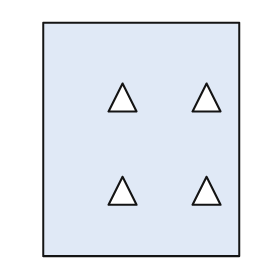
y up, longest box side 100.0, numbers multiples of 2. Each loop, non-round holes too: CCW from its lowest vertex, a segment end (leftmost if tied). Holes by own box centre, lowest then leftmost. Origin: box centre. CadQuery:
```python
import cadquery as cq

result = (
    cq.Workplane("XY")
    .moveTo(-42.0, -50.0)
    .lineTo(42.0, -50.0)
    .lineTo(42.0, 50.0)
    .lineTo(-42.0, 50.0)
    .close()
    .moveTo(-14.0, -28.0)
    .lineTo(-2.0, -28.0)
    .lineTo(-8.0, -16.0)
    .close()
    .moveTo(22.0, -28.0)
    .lineTo(34.0, -28.0)
    .lineTo(28.0, -16.0)
    .close()
    .moveTo(-14.0, 12.0)
    .lineTo(-2.0, 12.0)
    .lineTo(-8.0, 24.0)
    .close()
    .moveTo(22.0, 12.0)
    .lineTo(34.0, 12.0)
    .lineTo(28.0, 24.0)
    .close()
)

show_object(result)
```